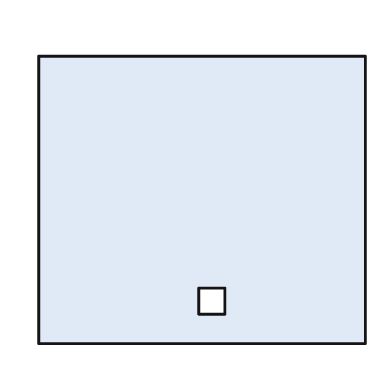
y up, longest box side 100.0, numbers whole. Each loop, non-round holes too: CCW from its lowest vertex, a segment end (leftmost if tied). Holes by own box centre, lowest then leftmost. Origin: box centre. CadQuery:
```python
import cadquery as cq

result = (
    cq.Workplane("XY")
    .moveTo(-50.0, -44.0)
    .lineTo(50.0, -44.0)
    .lineTo(50.0, 44.0)
    .lineTo(-50.0, 44.0)
    .close()
    .moveTo(-1.0, -35.0)
    .lineTo(7.0, -35.0)
    .lineTo(7.0, -27.0)
    .lineTo(-1.0, -27.0)
    .close()
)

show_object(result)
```